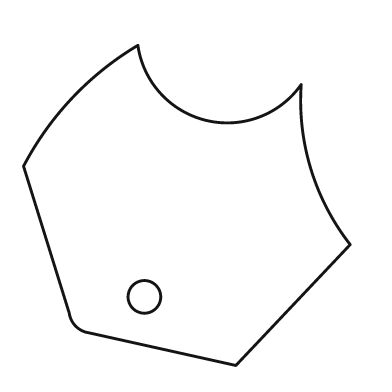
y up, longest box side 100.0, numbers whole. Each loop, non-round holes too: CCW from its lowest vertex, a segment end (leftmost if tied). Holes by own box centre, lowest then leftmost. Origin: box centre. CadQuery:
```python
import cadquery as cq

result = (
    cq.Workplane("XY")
    .moveTo(15.0, -49.0)
    .lineTo(50.0, -12.0)
    .threePointArc((38.0, 11.0), (35.0, 37.0))
    .threePointArc((6.0, 26.0), (-15.0, 49.0))
    .threePointArc((-35.0, 33.0), (-50.0, 12.0))
    .lineTo(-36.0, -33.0)
    .threePointArc((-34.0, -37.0), (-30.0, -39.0))
    .close()
    .moveTo(-13.0, -28.0)
    .circle(5.0)
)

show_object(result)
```